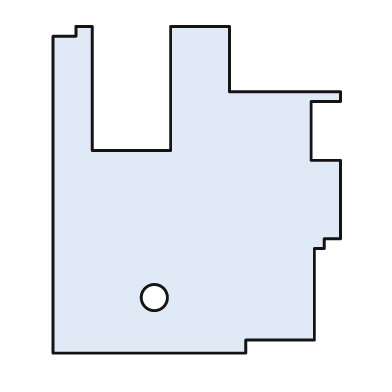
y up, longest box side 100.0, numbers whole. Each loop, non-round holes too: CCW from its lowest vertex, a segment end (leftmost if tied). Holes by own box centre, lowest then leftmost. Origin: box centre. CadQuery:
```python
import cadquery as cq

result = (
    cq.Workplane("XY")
    .moveTo(-44.0, -50.0)
    .lineTo(15.0, -50.0)
    .lineTo(15.0, -46.0)
    .lineTo(36.0, -46.0)
    .lineTo(36.0, -18.0)
    .lineTo(39.0, -18.0)
    .lineTo(39.0, -15.0)
    .lineTo(44.0, -15.0)
    .lineTo(44.0, 9.0)
    .lineTo(35.0, 9.0)
    .lineTo(35.0, 27.0)
    .lineTo(44.0, 27.0)
    .lineTo(44.0, 30.0)
    .lineTo(10.0, 30.0)
    .lineTo(10.0, 50.0)
    .lineTo(-8.0, 50.0)
    .lineTo(-8.0, 12.0)
    .lineTo(-32.0, 12.0)
    .lineTo(-32.0, 50.0)
    .lineTo(-37.0, 50.0)
    .lineTo(-37.0, 47.0)
    .lineTo(-44.0, 47.0)
    .close()
    .moveTo(-13.0, -33.0)
    .circle(4.0)
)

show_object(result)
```